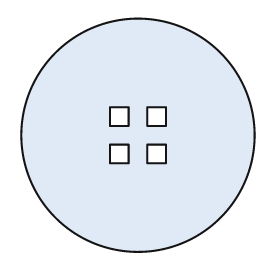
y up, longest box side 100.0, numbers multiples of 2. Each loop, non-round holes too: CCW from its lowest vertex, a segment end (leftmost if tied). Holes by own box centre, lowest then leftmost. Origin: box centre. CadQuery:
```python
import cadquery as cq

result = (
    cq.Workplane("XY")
    .moveTo(0.0, 0.0)
    .circle(50.0)
    .moveTo(-12.0, -12.0)
    .lineTo(-4.0, -12.0)
    .lineTo(-4.0, -4.0)
    .lineTo(-12.0, -4.0)
    .close()
    .moveTo(4.0, -12.0)
    .lineTo(12.0, -12.0)
    .lineTo(12.0, -4.0)
    .lineTo(4.0, -4.0)
    .close()
    .moveTo(-12.0, 4.0)
    .lineTo(-4.0, 4.0)
    .lineTo(-4.0, 12.0)
    .lineTo(-12.0, 12.0)
    .close()
    .moveTo(4.0, 4.0)
    .lineTo(12.0, 4.0)
    .lineTo(12.0, 12.0)
    .lineTo(4.0, 12.0)
    .close()
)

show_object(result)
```